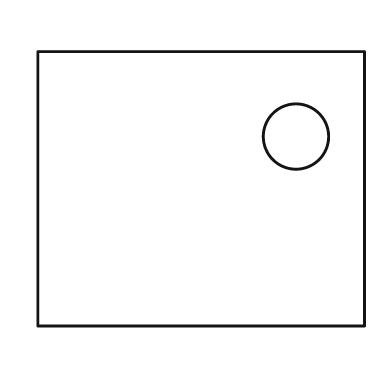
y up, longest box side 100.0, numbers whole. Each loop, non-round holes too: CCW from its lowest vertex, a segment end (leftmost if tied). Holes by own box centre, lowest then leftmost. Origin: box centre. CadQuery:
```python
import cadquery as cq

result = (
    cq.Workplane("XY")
    .moveTo(-50.0, -42.0)
    .lineTo(50.0, -42.0)
    .lineTo(50.0, 42.0)
    .lineTo(-50.0, 42.0)
    .close()
    .moveTo(29.0, 16.0)
    .circle(10.0)
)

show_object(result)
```